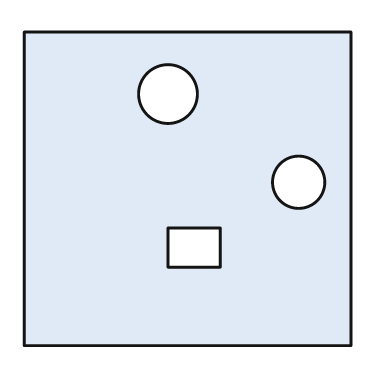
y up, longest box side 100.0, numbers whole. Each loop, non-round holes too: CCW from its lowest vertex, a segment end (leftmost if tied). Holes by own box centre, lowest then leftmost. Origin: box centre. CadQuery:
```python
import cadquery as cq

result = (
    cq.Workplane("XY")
    .moveTo(-50.0, -48.0)
    .lineTo(50.0, -48.0)
    .lineTo(50.0, 48.0)
    .lineTo(-50.0, 48.0)
    .close()
    .moveTo(-6.0, -24.0)
    .lineTo(10.0, -24.0)
    .lineTo(10.0, -12.0)
    .lineTo(-6.0, -12.0)
    .close()
    .moveTo(34.0, 2.0)
    .circle(8.0)
    .moveTo(-6.0, 29.0)
    .circle(9.0)
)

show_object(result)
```